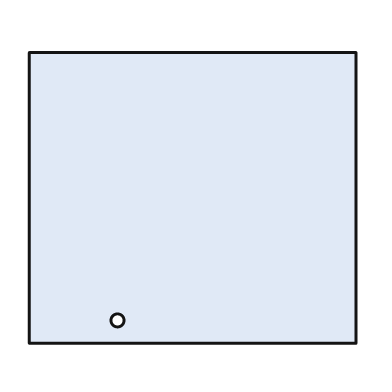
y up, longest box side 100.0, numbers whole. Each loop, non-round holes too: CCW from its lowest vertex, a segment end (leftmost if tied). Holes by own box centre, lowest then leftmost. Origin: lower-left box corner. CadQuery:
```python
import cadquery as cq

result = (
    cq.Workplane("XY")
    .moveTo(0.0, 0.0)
    .lineTo(100.0, 0.0)
    .lineTo(100.0, 89.0)
    .lineTo(0.0, 89.0)
    .close()
    .moveTo(27.0, 7.0)
    .circle(2.0)
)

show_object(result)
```